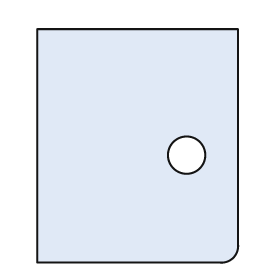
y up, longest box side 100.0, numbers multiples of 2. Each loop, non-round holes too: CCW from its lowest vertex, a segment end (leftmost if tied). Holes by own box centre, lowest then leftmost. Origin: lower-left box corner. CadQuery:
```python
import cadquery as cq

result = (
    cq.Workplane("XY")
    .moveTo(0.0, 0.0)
    .lineTo(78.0, 0.0)
    .threePointArc((84.0, 2.0), (86.0, 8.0))
    .lineTo(86.0, 100.0)
    .lineTo(0.0, 100.0)
    .close()
    .moveTo(64.0, 46.0)
    .circle(8.0)
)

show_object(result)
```